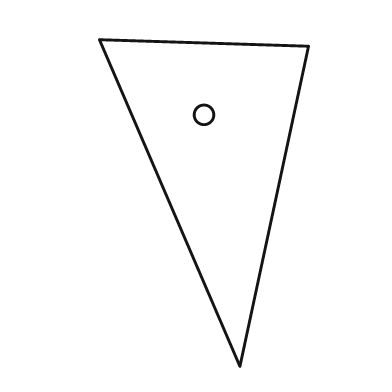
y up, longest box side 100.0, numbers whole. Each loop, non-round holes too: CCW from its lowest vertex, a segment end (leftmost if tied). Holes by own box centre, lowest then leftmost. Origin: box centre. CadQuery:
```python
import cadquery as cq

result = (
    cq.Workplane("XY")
    .moveTo(11.0, -50.0)
    .lineTo(32.0, 48.0)
    .lineTo(-32.0, 50.0)
    .close()
    .moveTo(0.0, 27.0)
    .circle(3.0)
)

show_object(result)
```